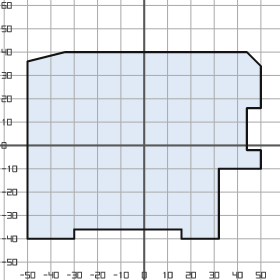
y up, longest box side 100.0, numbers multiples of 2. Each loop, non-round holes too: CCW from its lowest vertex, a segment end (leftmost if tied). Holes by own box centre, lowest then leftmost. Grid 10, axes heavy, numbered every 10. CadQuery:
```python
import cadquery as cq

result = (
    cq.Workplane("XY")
    .moveTo(-50.0, -40.0)
    .lineTo(-30.0, -40.0)
    .lineTo(-30.0, -36.0)
    .lineTo(16.0, -36.0)
    .lineTo(16.0, -40.0)
    .lineTo(32.0, -40.0)
    .lineTo(32.0, -10.0)
    .lineTo(50.0, -10.0)
    .lineTo(50.0, -2.0)
    .lineTo(44.0, -2.0)
    .lineTo(44.0, 16.0)
    .lineTo(50.0, 16.0)
    .lineTo(50.0, 34.0)
    .lineTo(44.0, 40.0)
    .lineTo(-34.0, 40.0)
    .lineTo(-50.0, 36.0)
    .close()
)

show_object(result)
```